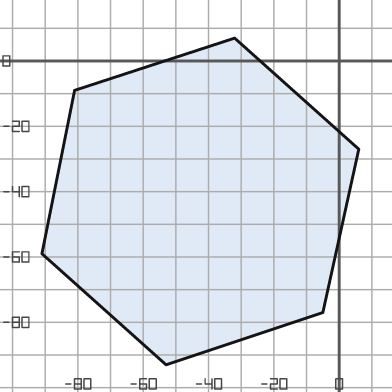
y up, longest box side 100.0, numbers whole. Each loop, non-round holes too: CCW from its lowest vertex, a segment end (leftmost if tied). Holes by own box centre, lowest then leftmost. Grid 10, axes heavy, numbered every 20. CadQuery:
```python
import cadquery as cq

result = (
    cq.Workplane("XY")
    .moveTo(-53.0, -93.0)
    .lineTo(-5.0, -77.0)
    .lineTo(6.0, -27.0)
    .lineTo(-32.0, 7.0)
    .lineTo(-81.0, -9.0)
    .lineTo(-91.0, -59.0)
    .close()
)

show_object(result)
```